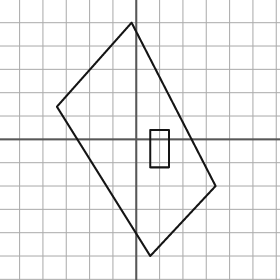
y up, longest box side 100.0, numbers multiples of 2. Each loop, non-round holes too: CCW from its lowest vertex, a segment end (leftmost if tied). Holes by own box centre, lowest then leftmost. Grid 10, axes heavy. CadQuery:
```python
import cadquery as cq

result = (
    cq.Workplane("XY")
    .moveTo(6.0, -50.0)
    .lineTo(34.0, -20.0)
    .lineTo(-2.0, 50.0)
    .lineTo(-34.0, 14.0)
    .close()
    .moveTo(6.0, -12.0)
    .lineTo(14.0, -12.0)
    .lineTo(14.0, 4.0)
    .lineTo(6.0, 4.0)
    .close()
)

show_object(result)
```